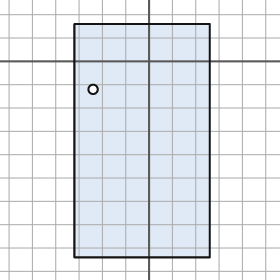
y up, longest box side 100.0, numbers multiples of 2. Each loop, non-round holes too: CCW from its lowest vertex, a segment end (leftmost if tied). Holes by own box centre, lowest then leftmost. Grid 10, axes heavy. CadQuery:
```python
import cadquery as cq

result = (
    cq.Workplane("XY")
    .moveTo(-32.0, -84.0)
    .lineTo(26.0, -84.0)
    .lineTo(26.0, 16.0)
    .lineTo(-32.0, 16.0)
    .close()
    .moveTo(-24.0, -12.0)
    .circle(2.0)
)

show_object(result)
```